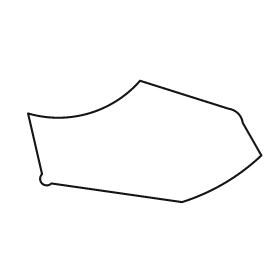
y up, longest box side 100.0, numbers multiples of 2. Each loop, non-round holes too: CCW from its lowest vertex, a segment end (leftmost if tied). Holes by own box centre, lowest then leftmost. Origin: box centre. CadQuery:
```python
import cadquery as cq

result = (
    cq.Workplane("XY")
    .moveTo(16.0, -26.0)
    .threePointArc((34.0, -18.0), (50.0, -6.0))
    .lineTo(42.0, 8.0)
    .threePointArc((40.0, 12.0), (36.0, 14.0))
    .lineTo(-2.0, 26.0)
    .threePointArc((-24.0, 12.0), (-50.0, 12.0))
    .lineTo(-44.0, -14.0)
    .threePointArc((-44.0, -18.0), (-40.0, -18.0))
    .close()
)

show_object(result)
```